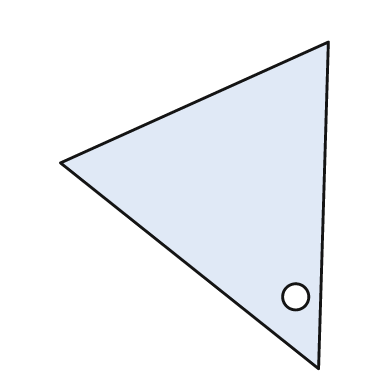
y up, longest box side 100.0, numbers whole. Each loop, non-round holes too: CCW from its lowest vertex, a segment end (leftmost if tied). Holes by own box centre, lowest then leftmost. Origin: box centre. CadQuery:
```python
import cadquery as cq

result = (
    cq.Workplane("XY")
    .moveTo(38.0, -50.0)
    .lineTo(41.0, 50.0)
    .lineTo(-41.0, 13.0)
    .close()
    .moveTo(31.0, -28.0)
    .circle(4.0)
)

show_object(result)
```